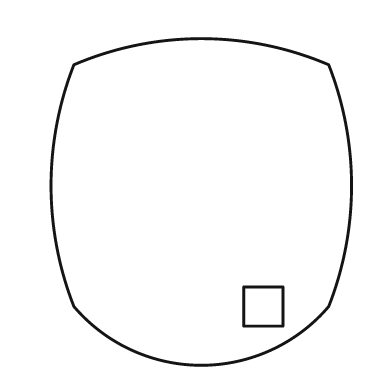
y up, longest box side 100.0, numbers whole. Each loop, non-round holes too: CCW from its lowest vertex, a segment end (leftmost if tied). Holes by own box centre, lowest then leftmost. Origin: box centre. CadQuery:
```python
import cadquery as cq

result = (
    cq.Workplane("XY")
    .moveTo(-39.0, -32.0)
    .threePointArc((0.0, -50.0), (39.0, -32.0))
    .threePointArc((46.0, 5.0), (39.0, 42.0))
    .threePointArc((0.0, 50.0), (-39.0, 42.0))
    .threePointArc((-46.0, 5.0), (-39.0, -32.0))
    .close()
    .moveTo(13.0, -38.0)
    .lineTo(25.0, -38.0)
    .lineTo(25.0, -26.0)
    .lineTo(13.0, -26.0)
    .close()
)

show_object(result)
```